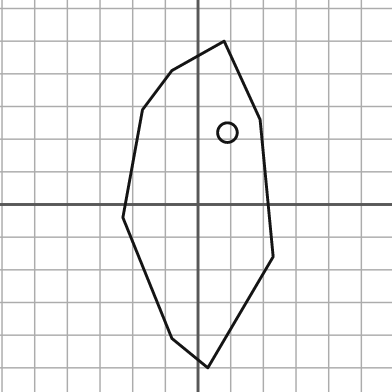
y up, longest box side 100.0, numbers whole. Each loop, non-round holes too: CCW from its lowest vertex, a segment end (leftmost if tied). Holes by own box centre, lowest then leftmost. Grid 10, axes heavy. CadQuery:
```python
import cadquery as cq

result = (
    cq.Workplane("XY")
    .moveTo(3.0, -50.0)
    .lineTo(23.0, -16.0)
    .lineTo(19.0, 26.0)
    .lineTo(8.0, 50.0)
    .lineTo(-8.0, 41.0)
    .lineTo(-17.0, 29.0)
    .lineTo(-23.0, -4.0)
    .lineTo(-8.0, -41.0)
    .close()
    .moveTo(9.0, 22.0)
    .circle(3.0)
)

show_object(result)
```